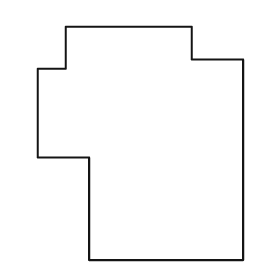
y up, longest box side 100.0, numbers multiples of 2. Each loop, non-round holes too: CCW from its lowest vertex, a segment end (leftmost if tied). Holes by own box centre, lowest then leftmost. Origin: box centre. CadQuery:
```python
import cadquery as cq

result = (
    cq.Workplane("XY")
    .moveTo(-22.0, -50.0)
    .lineTo(44.0, -50.0)
    .lineTo(44.0, 36.0)
    .lineTo(22.0, 36.0)
    .lineTo(22.0, 50.0)
    .lineTo(-32.0, 50.0)
    .lineTo(-32.0, 32.0)
    .lineTo(-44.0, 32.0)
    .lineTo(-44.0, -6.0)
    .lineTo(-22.0, -6.0)
    .close()
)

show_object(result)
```